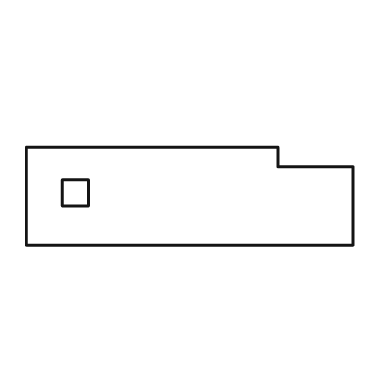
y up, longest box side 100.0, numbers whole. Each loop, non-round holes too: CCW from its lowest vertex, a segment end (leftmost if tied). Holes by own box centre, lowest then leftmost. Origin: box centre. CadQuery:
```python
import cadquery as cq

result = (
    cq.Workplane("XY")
    .moveTo(-50.0, -15.0)
    .lineTo(50.0, -15.0)
    .lineTo(50.0, 9.0)
    .lineTo(27.0, 9.0)
    .lineTo(27.0, 15.0)
    .lineTo(-50.0, 15.0)
    .close()
    .moveTo(-39.0, -3.0)
    .lineTo(-31.0, -3.0)
    .lineTo(-31.0, 5.0)
    .lineTo(-39.0, 5.0)
    .close()
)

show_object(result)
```